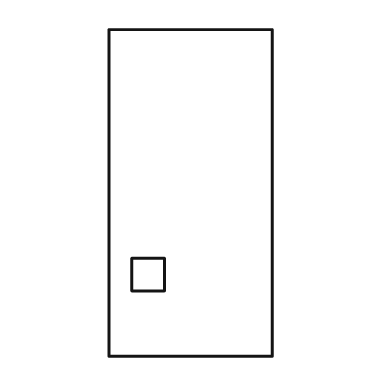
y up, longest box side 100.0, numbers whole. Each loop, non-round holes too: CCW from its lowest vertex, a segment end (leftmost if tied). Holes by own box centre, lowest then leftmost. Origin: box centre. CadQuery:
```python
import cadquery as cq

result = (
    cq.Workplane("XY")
    .moveTo(-25.0, -50.0)
    .lineTo(25.0, -50.0)
    .lineTo(25.0, 50.0)
    .lineTo(-25.0, 50.0)
    .close()
    .moveTo(-18.0, -30.0)
    .lineTo(-8.0, -30.0)
    .lineTo(-8.0, -20.0)
    .lineTo(-18.0, -20.0)
    .close()
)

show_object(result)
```